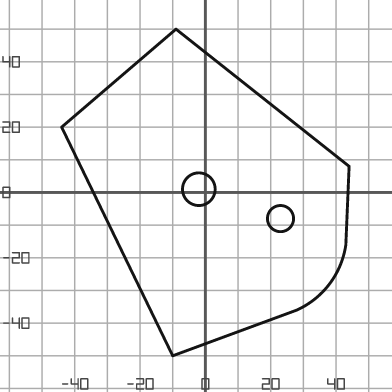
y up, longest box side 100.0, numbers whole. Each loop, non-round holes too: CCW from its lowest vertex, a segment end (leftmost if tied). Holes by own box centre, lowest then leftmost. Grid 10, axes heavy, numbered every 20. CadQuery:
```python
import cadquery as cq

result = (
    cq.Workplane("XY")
    .moveTo(-10.0, -50.0)
    .lineTo(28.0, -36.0)
    .threePointArc((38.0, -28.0), (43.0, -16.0))
    .lineTo(44.0, 8.0)
    .lineTo(-9.0, 50.0)
    .lineTo(-44.0, 20.0)
    .close()
    .moveTo(23.0, -8.0)
    .circle(4.0)
    .moveTo(-2.0, 1.0)
    .circle(5.0)
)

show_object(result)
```